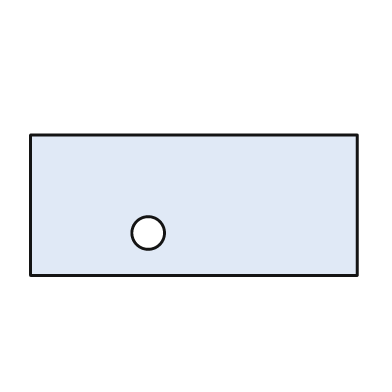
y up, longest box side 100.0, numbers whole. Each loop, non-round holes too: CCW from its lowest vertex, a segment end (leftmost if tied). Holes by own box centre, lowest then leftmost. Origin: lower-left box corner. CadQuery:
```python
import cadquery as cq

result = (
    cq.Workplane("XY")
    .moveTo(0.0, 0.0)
    .lineTo(100.0, 0.0)
    .lineTo(100.0, 43.0)
    .lineTo(0.0, 43.0)
    .close()
    .moveTo(36.0, 13.0)
    .circle(5.0)
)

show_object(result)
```